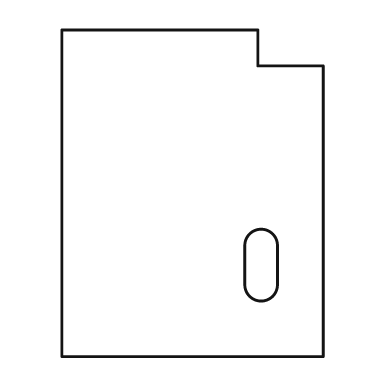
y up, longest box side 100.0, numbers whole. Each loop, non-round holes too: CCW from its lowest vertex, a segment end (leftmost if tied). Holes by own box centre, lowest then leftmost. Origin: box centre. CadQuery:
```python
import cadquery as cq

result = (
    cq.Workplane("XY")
    .moveTo(-40.0, -50.0)
    .lineTo(40.0, -50.0)
    .lineTo(40.0, 39.0)
    .lineTo(20.0, 39.0)
    .lineTo(20.0, 50.0)
    .lineTo(-40.0, 50.0)
    .close()
    .moveTo(16.0, -28.0)
    .threePointArc((21.0, -33.0), (26.0, -28.0))
    .lineTo(26.0, -16.0)
    .threePointArc((21.0, -11.0), (16.0, -16.0))
    .close()
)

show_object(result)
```